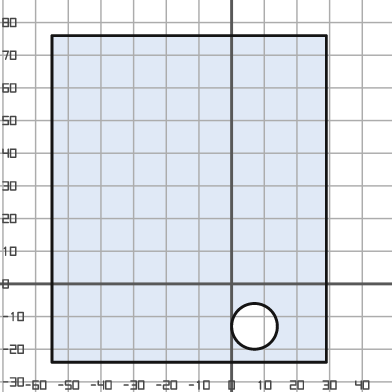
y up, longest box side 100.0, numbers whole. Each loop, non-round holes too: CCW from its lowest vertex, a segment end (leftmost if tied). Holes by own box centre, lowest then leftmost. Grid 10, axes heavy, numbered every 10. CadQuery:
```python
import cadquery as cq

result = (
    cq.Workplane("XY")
    .moveTo(-55.0, -24.0)
    .lineTo(29.0, -24.0)
    .lineTo(29.0, 76.0)
    .lineTo(-55.0, 76.0)
    .close()
    .moveTo(7.0, -13.0)
    .circle(7.0)
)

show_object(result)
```